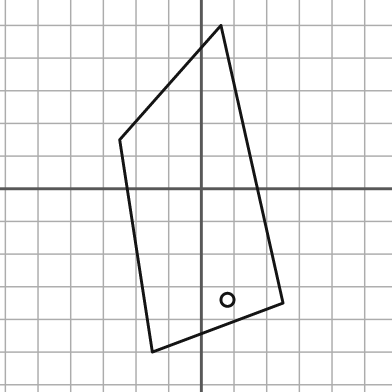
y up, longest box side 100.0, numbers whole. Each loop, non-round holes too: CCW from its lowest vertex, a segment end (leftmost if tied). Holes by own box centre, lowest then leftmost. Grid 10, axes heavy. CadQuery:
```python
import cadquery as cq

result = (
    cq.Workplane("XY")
    .moveTo(-15.0, -50.0)
    .lineTo(25.0, -35.0)
    .lineTo(6.0, 50.0)
    .lineTo(-25.0, 15.0)
    .close()
    .moveTo(8.0, -34.0)
    .circle(2.0)
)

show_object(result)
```